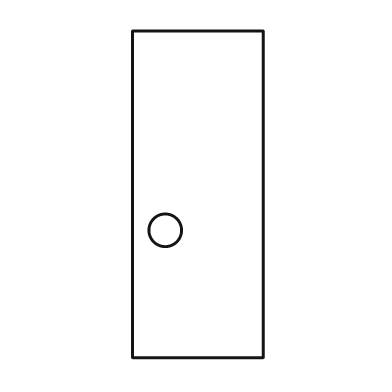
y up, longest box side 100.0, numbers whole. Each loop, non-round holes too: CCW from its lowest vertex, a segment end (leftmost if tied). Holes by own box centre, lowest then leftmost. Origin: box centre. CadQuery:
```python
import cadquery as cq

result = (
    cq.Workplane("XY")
    .moveTo(-20.0, -50.0)
    .lineTo(20.0, -50.0)
    .lineTo(20.0, 50.0)
    .lineTo(-20.0, 50.0)
    .close()
    .moveTo(-10.0, -11.0)
    .circle(5.0)
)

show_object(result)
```